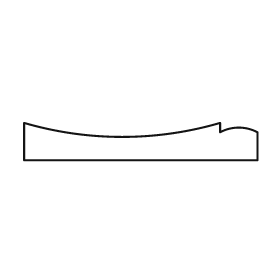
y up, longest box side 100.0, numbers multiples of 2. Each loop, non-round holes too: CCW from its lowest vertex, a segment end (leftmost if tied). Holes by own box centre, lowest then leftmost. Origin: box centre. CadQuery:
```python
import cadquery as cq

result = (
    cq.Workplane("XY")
    .moveTo(-50.0, -8.0)
    .lineTo(50.0, -8.0)
    .lineTo(50.0, 4.0)
    .threePointArc((42.0, 6.0), (34.0, 4.0))
    .lineTo(34.0, 8.0)
    .threePointArc((-8.0, 2.0), (-50.0, 8.0))
    .close()
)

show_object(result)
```